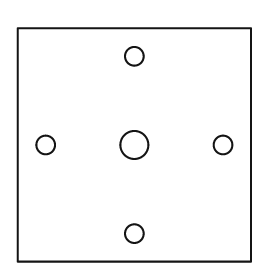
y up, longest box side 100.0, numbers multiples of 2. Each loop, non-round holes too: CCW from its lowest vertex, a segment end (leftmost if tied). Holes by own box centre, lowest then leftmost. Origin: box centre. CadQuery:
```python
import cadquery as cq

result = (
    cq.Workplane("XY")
    .moveTo(-50.0, -50.0)
    .lineTo(50.0, -50.0)
    .lineTo(50.0, 50.0)
    .lineTo(-50.0, 50.0)
    .close()
    .moveTo(0.0, -38.0)
    .circle(4.0)
    .moveTo(-38.0, 0.0)
    .circle(4.0)
    .moveTo(0.0, 0.0)
    .circle(6.0)
    .moveTo(38.0, 0.0)
    .circle(4.0)
    .moveTo(0.0, 38.0)
    .circle(4.0)
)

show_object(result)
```